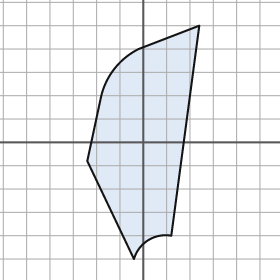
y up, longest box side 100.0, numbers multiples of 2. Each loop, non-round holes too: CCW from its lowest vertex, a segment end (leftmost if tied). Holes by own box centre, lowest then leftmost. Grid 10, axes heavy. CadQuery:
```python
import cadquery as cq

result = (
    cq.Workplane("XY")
    .moveTo(-4.0, -50.0)
    .threePointArc((2.0, -42.0), (12.0, -40.0))
    .lineTo(24.0, 50.0)
    .lineTo(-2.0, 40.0)
    .threePointArc((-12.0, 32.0), (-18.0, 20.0))
    .lineTo(-24.0, -8.0)
    .close()
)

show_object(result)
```